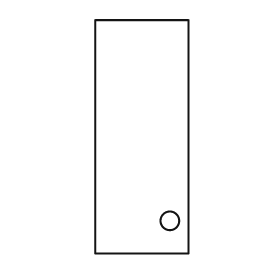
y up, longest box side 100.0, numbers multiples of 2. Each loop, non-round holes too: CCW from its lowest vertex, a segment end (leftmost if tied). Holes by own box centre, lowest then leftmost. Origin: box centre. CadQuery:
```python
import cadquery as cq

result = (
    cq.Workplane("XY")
    .moveTo(-20.0, -50.0)
    .lineTo(20.0, -50.0)
    .lineTo(20.0, 50.0)
    .lineTo(-20.0, 50.0)
    .close()
    .moveTo(12.0, -36.0)
    .circle(4.0)
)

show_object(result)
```